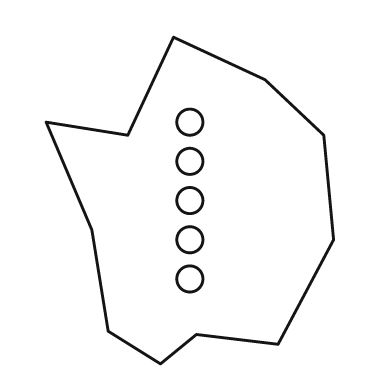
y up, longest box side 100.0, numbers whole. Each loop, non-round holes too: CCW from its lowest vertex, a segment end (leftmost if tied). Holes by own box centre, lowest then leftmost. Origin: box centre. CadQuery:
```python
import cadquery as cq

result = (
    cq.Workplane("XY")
    .moveTo(-9.0, -50.0)
    .lineTo(2.0, -41.0)
    .lineTo(27.0, -44.0)
    .lineTo(44.0, -12.0)
    .lineTo(41.0, 20.0)
    .lineTo(23.0, 37.0)
    .lineTo(-5.0, 50.0)
    .lineTo(-19.0, 20.0)
    .lineTo(-44.0, 24.0)
    .lineTo(-30.0, -9.0)
    .lineTo(-25.0, -40.0)
    .close()
    .moveTo(0.0, -24.0)
    .circle(4.0)
    .moveTo(0.0, -12.0)
    .circle(4.0)
    .moveTo(0.0, 0.0)
    .circle(4.0)
    .moveTo(0.0, 12.0)
    .circle(4.0)
    .moveTo(0.0, 24.0)
    .circle(4.0)
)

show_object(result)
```